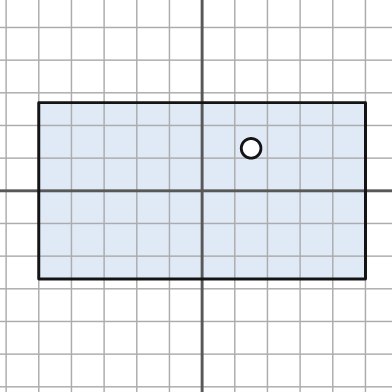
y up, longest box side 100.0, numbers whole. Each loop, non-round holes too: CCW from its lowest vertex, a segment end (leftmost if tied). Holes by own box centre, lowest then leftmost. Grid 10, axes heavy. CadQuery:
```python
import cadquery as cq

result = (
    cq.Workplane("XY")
    .moveTo(-50.0, -27.0)
    .lineTo(50.0, -27.0)
    .lineTo(50.0, 27.0)
    .lineTo(-50.0, 27.0)
    .close()
    .moveTo(15.0, 13.0)
    .circle(3.0)
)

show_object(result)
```